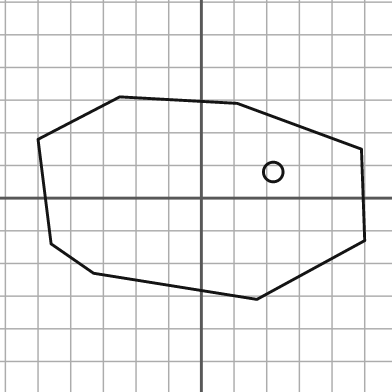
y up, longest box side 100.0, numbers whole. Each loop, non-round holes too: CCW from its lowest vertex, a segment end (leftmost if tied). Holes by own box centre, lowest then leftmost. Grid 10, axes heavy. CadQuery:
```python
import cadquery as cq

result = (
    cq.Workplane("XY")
    .moveTo(17.0, -31.0)
    .lineTo(50.0, -13.0)
    .lineTo(49.0, 15.0)
    .lineTo(11.0, 29.0)
    .lineTo(-25.0, 31.0)
    .lineTo(-50.0, 18.0)
    .lineTo(-46.0, -14.0)
    .lineTo(-33.0, -23.0)
    .close()
    .moveTo(22.0, 8.0)
    .circle(3.0)
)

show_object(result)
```